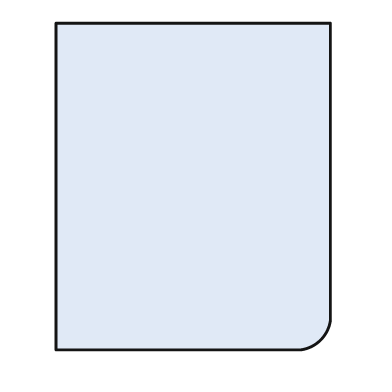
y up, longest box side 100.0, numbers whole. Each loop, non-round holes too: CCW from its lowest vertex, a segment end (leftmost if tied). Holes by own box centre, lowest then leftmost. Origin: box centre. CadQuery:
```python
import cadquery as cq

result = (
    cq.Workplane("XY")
    .moveTo(-42.0, -50.0)
    .lineTo(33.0, -50.0)
    .threePointArc((39.0, -47.0), (42.0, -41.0))
    .lineTo(42.0, 50.0)
    .lineTo(-42.0, 50.0)
    .close()
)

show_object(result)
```